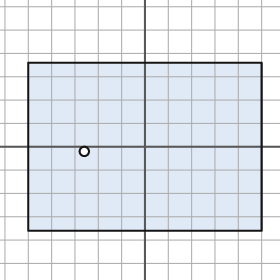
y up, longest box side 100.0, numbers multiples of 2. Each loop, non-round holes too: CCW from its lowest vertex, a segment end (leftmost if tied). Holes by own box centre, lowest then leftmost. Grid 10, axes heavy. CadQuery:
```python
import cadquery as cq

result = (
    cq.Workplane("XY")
    .moveTo(-50.0, -36.0)
    .lineTo(50.0, -36.0)
    .lineTo(50.0, 36.0)
    .lineTo(-50.0, 36.0)
    .close()
    .moveTo(-26.0, -2.0)
    .circle(2.0)
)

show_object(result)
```